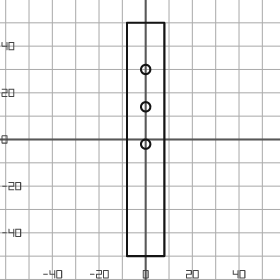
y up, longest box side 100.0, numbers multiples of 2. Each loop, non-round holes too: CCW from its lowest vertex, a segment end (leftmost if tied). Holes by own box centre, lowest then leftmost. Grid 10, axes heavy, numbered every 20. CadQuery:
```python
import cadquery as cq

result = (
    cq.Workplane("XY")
    .moveTo(-8.0, -50.0)
    .lineTo(8.0, -50.0)
    .lineTo(8.0, 50.0)
    .lineTo(-8.0, 50.0)
    .close()
    .moveTo(0.0, -2.0)
    .circle(2.0)
    .moveTo(0.0, 14.0)
    .circle(2.0)
    .moveTo(0.0, 30.0)
    .circle(2.0)
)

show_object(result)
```